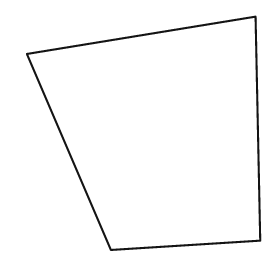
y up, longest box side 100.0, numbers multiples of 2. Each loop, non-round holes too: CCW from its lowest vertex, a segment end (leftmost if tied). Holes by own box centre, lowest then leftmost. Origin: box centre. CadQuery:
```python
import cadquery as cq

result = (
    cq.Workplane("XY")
    .moveTo(-14.0, -50.0)
    .lineTo(50.0, -46.0)
    .lineTo(48.0, 50.0)
    .lineTo(-50.0, 34.0)
    .close()
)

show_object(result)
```